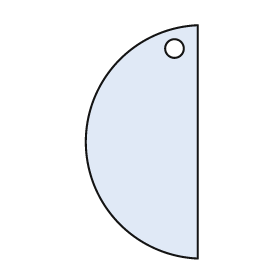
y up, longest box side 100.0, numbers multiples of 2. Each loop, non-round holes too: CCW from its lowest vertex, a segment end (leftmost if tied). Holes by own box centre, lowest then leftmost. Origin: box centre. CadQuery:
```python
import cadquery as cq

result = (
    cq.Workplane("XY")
    .moveTo(24.0, -50.0)
    .lineTo(24.0, 50.0)
    .threePointArc((-24.0, 0.0), (24.0, -50.0))
    .close()
    .moveTo(14.0, 40.0)
    .circle(4.0)
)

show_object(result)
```